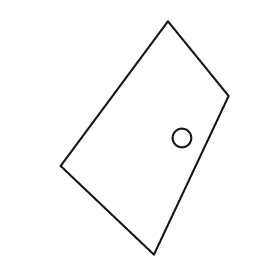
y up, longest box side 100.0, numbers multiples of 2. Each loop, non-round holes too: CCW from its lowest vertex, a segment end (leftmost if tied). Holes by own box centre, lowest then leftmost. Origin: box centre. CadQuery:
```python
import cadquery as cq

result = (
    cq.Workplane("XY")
    .moveTo(4.0, -50.0)
    .lineTo(36.0, 18.0)
    .lineTo(10.0, 50.0)
    .lineTo(-36.0, -12.0)
    .close()
    .moveTo(16.0, 0.0)
    .circle(4.0)
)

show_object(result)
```